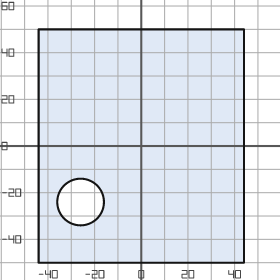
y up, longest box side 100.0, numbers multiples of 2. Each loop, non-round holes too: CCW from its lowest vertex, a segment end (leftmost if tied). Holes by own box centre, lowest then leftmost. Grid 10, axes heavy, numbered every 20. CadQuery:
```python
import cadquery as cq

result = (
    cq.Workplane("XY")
    .moveTo(-44.0, -50.0)
    .lineTo(44.0, -50.0)
    .lineTo(44.0, 50.0)
    .lineTo(-44.0, 50.0)
    .close()
    .moveTo(-26.0, -24.0)
    .circle(10.0)
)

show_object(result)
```